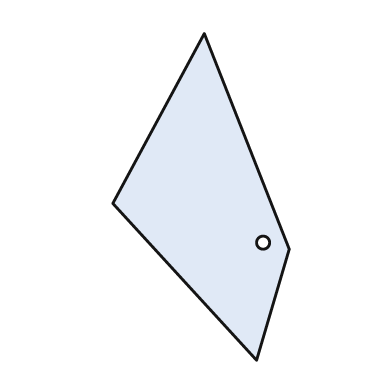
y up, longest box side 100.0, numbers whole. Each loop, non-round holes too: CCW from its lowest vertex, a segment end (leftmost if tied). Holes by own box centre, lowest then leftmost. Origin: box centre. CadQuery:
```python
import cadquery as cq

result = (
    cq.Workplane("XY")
    .moveTo(17.0, -50.0)
    .lineTo(27.0, -16.0)
    .lineTo(1.0, 50.0)
    .lineTo(-27.0, -2.0)
    .close()
    .moveTo(19.0, -14.0)
    .circle(2.0)
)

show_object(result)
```